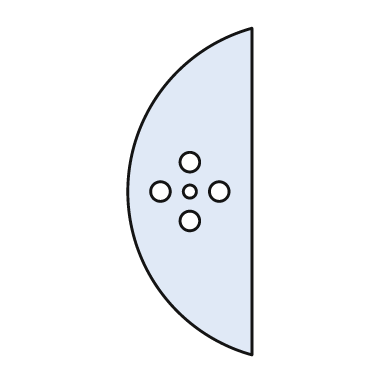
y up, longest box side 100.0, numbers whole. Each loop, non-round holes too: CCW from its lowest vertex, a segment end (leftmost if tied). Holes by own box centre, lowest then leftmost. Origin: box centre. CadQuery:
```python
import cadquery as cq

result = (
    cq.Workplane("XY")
    .moveTo(19.0, -50.0)
    .lineTo(19.0, 50.0)
    .threePointArc((-19.0, 0.0), (19.0, -50.0))
    .close()
    .moveTo(0.0, -9.0)
    .circle(3.0)
    .moveTo(-9.0, 0.0)
    .circle(3.0)
    .moveTo(0.0, 0.0)
    .circle(2.0)
    .moveTo(9.0, 0.0)
    .circle(3.0)
    .moveTo(0.0, 9.0)
    .circle(3.0)
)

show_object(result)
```